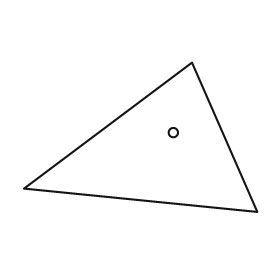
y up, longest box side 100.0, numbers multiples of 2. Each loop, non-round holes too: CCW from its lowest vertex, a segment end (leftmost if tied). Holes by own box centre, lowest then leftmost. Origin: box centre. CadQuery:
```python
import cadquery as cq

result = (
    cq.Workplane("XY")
    .moveTo(50.0, -32.0)
    .lineTo(22.0, 32.0)
    .lineTo(-50.0, -22.0)
    .close()
    .moveTo(14.0, 2.0)
    .circle(2.0)
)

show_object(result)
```